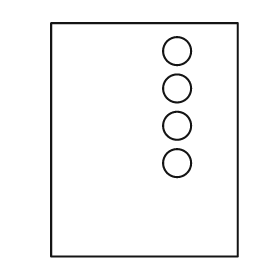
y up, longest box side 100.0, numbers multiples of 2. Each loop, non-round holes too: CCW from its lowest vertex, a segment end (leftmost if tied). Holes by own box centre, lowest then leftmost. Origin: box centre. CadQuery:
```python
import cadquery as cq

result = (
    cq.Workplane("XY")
    .moveTo(-40.0, -50.0)
    .lineTo(40.0, -50.0)
    .lineTo(40.0, 50.0)
    .lineTo(-40.0, 50.0)
    .close()
    .moveTo(14.0, -10.0)
    .circle(6.0)
    .moveTo(14.0, 6.0)
    .circle(6.0)
    .moveTo(14.0, 22.0)
    .circle(6.0)
    .moveTo(14.0, 38.0)
    .circle(6.0)
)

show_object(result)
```